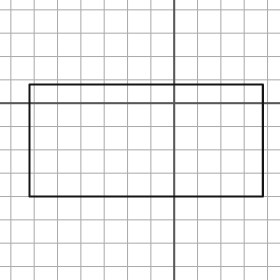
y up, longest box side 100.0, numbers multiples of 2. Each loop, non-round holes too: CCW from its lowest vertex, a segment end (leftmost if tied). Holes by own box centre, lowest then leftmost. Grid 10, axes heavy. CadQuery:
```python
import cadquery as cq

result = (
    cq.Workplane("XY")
    .moveTo(-62.0, -40.0)
    .lineTo(38.0, -40.0)
    .lineTo(38.0, 8.0)
    .lineTo(-62.0, 8.0)
    .close()
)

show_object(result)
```